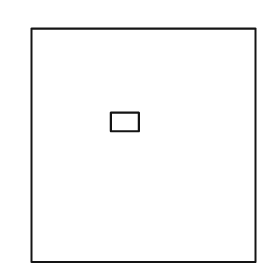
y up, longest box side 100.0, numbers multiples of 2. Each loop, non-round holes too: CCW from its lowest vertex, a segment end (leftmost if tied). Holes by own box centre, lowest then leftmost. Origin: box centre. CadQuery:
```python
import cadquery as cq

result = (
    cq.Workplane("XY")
    .moveTo(-48.0, -50.0)
    .lineTo(48.0, -50.0)
    .lineTo(48.0, 50.0)
    .lineTo(-48.0, 50.0)
    .close()
    .moveTo(-14.0, 6.0)
    .lineTo(-2.0, 6.0)
    .lineTo(-2.0, 14.0)
    .lineTo(-14.0, 14.0)
    .close()
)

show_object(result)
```